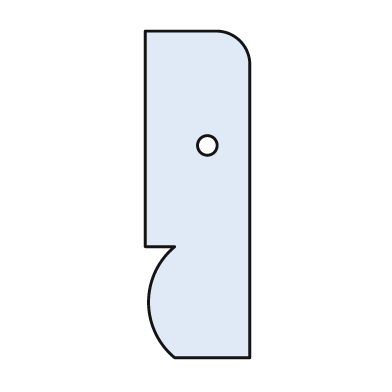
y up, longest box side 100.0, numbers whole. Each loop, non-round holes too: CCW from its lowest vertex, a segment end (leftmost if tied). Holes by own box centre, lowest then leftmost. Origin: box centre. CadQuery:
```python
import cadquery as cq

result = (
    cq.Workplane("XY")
    .moveTo(-7.0, -50.0)
    .lineTo(16.0, -50.0)
    .lineTo(16.0, 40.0)
    .threePointArc((13.0, 47.0), (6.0, 50.0))
    .lineTo(-16.0, 50.0)
    .lineTo(-16.0, -16.0)
    .lineTo(-7.0, -16.0)
    .threePointArc((-15.0, -33.0), (-7.0, -50.0))
    .close()
    .moveTo(3.0, 15.0)
    .circle(3.0)
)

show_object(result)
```